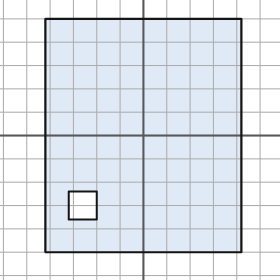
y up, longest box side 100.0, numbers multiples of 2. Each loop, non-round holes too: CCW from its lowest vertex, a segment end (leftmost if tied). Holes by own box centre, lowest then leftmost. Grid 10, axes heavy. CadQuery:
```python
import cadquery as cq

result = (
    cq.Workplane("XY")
    .moveTo(-42.0, -50.0)
    .lineTo(42.0, -50.0)
    .lineTo(42.0, 50.0)
    .lineTo(-42.0, 50.0)
    .close()
    .moveTo(-32.0, -36.0)
    .lineTo(-20.0, -36.0)
    .lineTo(-20.0, -24.0)
    .lineTo(-32.0, -24.0)
    .close()
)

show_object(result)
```